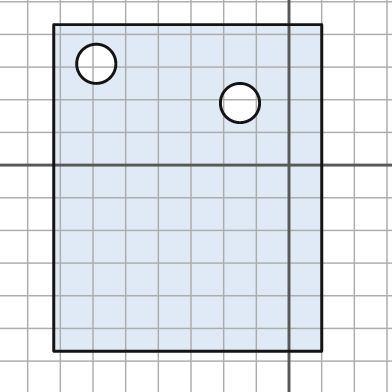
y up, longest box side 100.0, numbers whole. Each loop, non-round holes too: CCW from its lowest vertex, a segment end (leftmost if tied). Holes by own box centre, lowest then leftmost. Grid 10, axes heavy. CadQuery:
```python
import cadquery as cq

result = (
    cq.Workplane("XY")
    .moveTo(-72.0, -57.0)
    .lineTo(10.0, -57.0)
    .lineTo(10.0, 43.0)
    .lineTo(-72.0, 43.0)
    .close()
    .moveTo(-15.0, 19.0)
    .circle(6.0)
    .moveTo(-59.0, 31.0)
    .circle(6.0)
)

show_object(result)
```